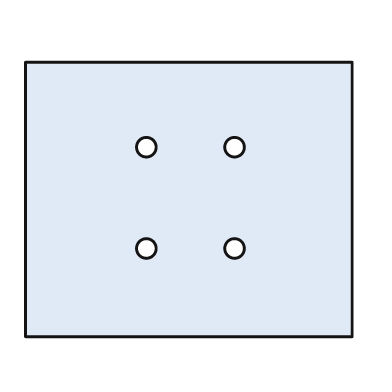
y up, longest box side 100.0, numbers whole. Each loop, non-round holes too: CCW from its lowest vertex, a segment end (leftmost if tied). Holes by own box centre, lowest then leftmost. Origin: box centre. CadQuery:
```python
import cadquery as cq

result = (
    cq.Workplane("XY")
    .moveTo(-50.0, -42.0)
    .lineTo(50.0, -42.0)
    .lineTo(50.0, 42.0)
    .lineTo(-50.0, 42.0)
    .close()
    .moveTo(-13.0, -15.0)
    .circle(3.0)
    .moveTo(14.0, -15.0)
    .circle(3.0)
    .moveTo(-13.0, 16.0)
    .circle(3.0)
    .moveTo(14.0, 16.0)
    .circle(3.0)
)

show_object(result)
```